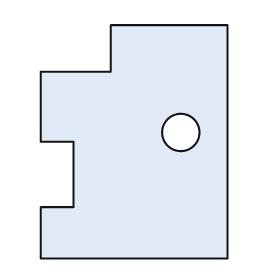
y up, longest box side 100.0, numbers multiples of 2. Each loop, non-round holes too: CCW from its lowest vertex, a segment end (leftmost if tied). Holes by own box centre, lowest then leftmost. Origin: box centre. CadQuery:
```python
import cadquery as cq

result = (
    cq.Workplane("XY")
    .moveTo(-40.0, -50.0)
    .lineTo(40.0, -50.0)
    .lineTo(40.0, 50.0)
    .lineTo(-10.0, 50.0)
    .lineTo(-10.0, 30.0)
    .lineTo(-40.0, 30.0)
    .lineTo(-40.0, 0.0)
    .lineTo(-26.0, 0.0)
    .lineTo(-26.0, -28.0)
    .lineTo(-40.0, -28.0)
    .close()
    .moveTo(20.0, 4.0)
    .circle(8.0)
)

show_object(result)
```